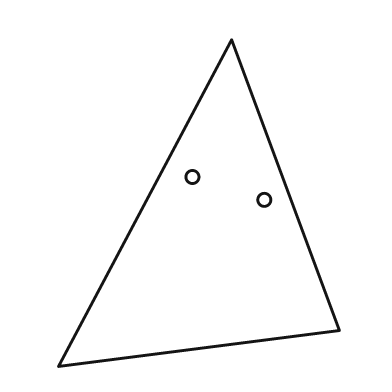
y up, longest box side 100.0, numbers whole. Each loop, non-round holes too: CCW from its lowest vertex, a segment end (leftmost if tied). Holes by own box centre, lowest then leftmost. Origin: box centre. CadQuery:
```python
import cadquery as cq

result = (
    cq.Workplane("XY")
    .moveTo(-43.0, -50.0)
    .lineTo(43.0, -39.0)
    .lineTo(10.0, 50.0)
    .close()
    .moveTo(20.0, 1.0)
    .circle(2.0)
    .moveTo(-2.0, 8.0)
    .circle(2.0)
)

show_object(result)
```